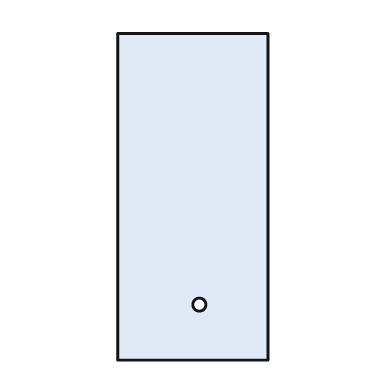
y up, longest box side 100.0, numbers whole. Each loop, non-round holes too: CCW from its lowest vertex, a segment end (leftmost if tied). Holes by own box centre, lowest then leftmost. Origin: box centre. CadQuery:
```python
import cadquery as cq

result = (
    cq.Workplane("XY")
    .moveTo(-23.0, -50.0)
    .lineTo(23.0, -50.0)
    .lineTo(23.0, 50.0)
    .lineTo(-23.0, 50.0)
    .close()
    .moveTo(2.0, -33.0)
    .circle(2.0)
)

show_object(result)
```